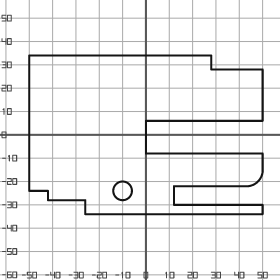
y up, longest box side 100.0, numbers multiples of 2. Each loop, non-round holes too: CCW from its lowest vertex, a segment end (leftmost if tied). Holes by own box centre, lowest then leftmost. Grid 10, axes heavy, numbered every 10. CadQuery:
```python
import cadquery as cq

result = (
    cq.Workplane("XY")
    .moveTo(-26.0, -34.0)
    .lineTo(50.0, -34.0)
    .lineTo(50.0, -30.0)
    .lineTo(12.0, -30.0)
    .lineTo(12.0, -22.0)
    .lineTo(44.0, -22.0)
    .threePointArc((48.0, -20.0), (50.0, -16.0))
    .lineTo(50.0, -8.0)
    .lineTo(0.0, -8.0)
    .lineTo(0.0, 6.0)
    .lineTo(50.0, 6.0)
    .lineTo(50.0, 28.0)
    .lineTo(28.0, 28.0)
    .lineTo(28.0, 34.0)
    .lineTo(-50.0, 34.0)
    .lineTo(-50.0, -24.0)
    .lineTo(-42.0, -24.0)
    .lineTo(-42.0, -28.0)
    .lineTo(-26.0, -28.0)
    .close()
    .moveTo(-10.0, -24.0)
    .circle(4.0)
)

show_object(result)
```